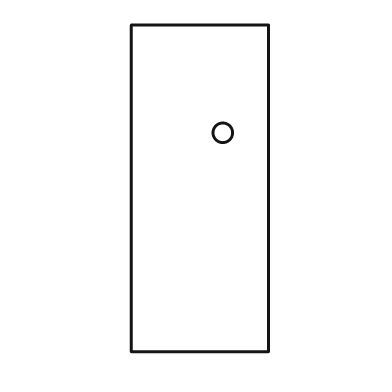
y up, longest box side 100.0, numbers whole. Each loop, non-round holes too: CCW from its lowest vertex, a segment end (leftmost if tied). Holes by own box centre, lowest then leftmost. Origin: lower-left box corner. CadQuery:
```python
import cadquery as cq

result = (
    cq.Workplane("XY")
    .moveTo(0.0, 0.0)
    .lineTo(42.0, 0.0)
    .lineTo(42.0, 100.0)
    .lineTo(0.0, 100.0)
    .close()
    .moveTo(28.0, 67.0)
    .circle(3.0)
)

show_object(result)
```